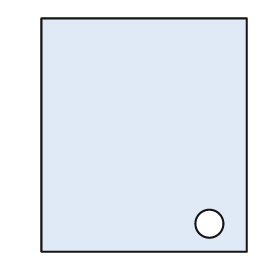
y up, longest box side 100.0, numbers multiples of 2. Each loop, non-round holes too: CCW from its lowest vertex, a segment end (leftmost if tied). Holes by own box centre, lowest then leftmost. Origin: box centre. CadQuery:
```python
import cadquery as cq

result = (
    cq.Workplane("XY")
    .moveTo(-44.0, -50.0)
    .lineTo(44.0, -50.0)
    .lineTo(44.0, 50.0)
    .lineTo(-44.0, 50.0)
    .close()
    .moveTo(28.0, -38.0)
    .circle(6.0)
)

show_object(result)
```